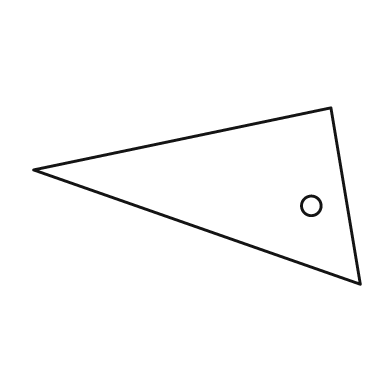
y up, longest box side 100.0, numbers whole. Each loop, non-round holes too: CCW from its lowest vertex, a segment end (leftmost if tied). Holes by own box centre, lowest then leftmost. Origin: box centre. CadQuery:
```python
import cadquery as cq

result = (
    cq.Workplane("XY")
    .moveTo(50.0, -27.0)
    .lineTo(41.0, 27.0)
    .lineTo(-50.0, 8.0)
    .close()
    .moveTo(35.0, -3.0)
    .circle(3.0)
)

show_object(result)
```